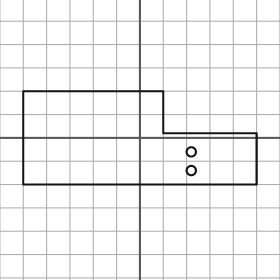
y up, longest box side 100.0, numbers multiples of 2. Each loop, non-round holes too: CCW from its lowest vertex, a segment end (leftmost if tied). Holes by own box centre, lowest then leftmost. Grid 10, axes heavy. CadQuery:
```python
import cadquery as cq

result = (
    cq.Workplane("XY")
    .moveTo(-50.0, -20.0)
    .lineTo(50.0, -20.0)
    .lineTo(50.0, 2.0)
    .lineTo(10.0, 2.0)
    .lineTo(10.0, 20.0)
    .lineTo(-50.0, 20.0)
    .close()
    .moveTo(22.0, -14.0)
    .circle(2.0)
    .moveTo(22.0, -6.0)
    .circle(2.0)
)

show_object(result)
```